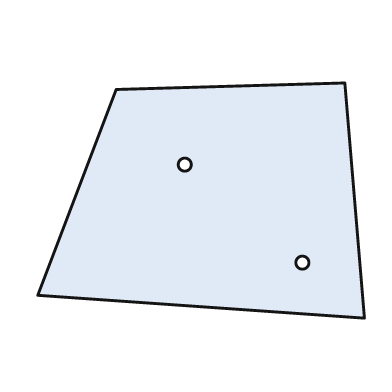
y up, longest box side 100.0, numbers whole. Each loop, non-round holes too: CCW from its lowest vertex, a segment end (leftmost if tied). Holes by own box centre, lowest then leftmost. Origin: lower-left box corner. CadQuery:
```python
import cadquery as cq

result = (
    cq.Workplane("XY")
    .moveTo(100.0, 0.0)
    .lineTo(94.0, 72.0)
    .lineTo(24.0, 70.0)
    .lineTo(0.0, 7.0)
    .close()
    .moveTo(81.0, 17.0)
    .circle(2.0)
    .moveTo(45.0, 47.0)
    .circle(2.0)
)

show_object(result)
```